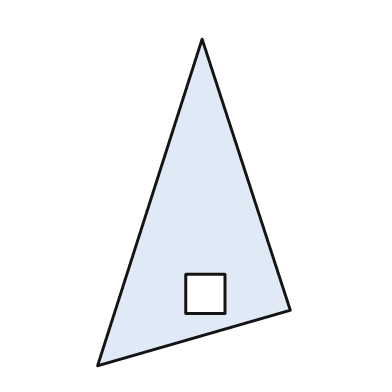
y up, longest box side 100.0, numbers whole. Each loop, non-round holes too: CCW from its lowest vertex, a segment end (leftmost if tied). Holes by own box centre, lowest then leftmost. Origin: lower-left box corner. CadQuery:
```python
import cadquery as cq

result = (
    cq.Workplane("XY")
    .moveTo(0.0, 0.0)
    .lineTo(59.0, 17.0)
    .lineTo(32.0, 100.0)
    .close()
    .moveTo(27.0, 16.0)
    .lineTo(39.0, 16.0)
    .lineTo(39.0, 28.0)
    .lineTo(27.0, 28.0)
    .close()
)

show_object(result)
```